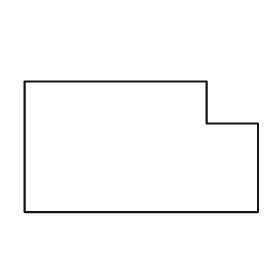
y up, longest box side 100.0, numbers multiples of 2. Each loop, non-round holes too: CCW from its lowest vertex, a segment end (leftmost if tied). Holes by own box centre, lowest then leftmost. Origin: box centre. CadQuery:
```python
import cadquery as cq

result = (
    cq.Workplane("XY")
    .moveTo(-50.0, -28.0)
    .lineTo(50.0, -28.0)
    .lineTo(50.0, 10.0)
    .lineTo(28.0, 10.0)
    .lineTo(28.0, 28.0)
    .lineTo(-50.0, 28.0)
    .close()
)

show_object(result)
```